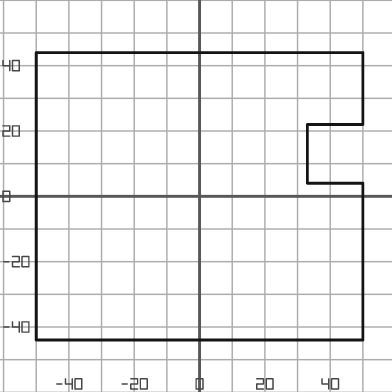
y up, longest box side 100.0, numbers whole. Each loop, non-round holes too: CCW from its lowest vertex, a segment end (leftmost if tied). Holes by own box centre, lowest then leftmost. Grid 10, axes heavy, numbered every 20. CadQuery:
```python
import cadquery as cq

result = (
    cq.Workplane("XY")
    .moveTo(-50.0, -44.0)
    .lineTo(50.0, -44.0)
    .lineTo(50.0, 4.0)
    .lineTo(33.0, 4.0)
    .lineTo(33.0, 22.0)
    .lineTo(50.0, 22.0)
    .lineTo(50.0, 44.0)
    .lineTo(-50.0, 44.0)
    .close()
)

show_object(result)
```